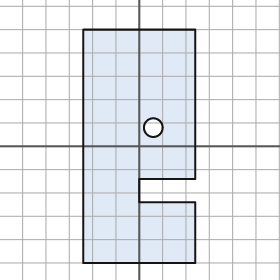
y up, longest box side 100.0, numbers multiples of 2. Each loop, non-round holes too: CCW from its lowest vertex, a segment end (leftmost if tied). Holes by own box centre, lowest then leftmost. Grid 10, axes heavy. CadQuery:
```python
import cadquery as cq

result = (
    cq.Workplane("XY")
    .moveTo(-24.0, -50.0)
    .lineTo(24.0, -50.0)
    .lineTo(24.0, -24.0)
    .lineTo(0.0, -24.0)
    .lineTo(0.0, -14.0)
    .lineTo(24.0, -14.0)
    .lineTo(24.0, 50.0)
    .lineTo(-24.0, 50.0)
    .close()
    .moveTo(6.0, 8.0)
    .circle(4.0)
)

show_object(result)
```